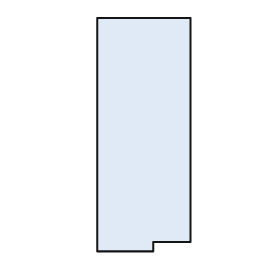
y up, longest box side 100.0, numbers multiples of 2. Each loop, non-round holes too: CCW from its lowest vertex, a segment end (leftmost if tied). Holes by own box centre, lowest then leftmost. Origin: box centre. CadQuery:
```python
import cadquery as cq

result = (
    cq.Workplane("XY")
    .moveTo(-20.0, -50.0)
    .lineTo(4.0, -50.0)
    .lineTo(4.0, -46.0)
    .lineTo(20.0, -46.0)
    .lineTo(20.0, 50.0)
    .lineTo(-20.0, 50.0)
    .close()
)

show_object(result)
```